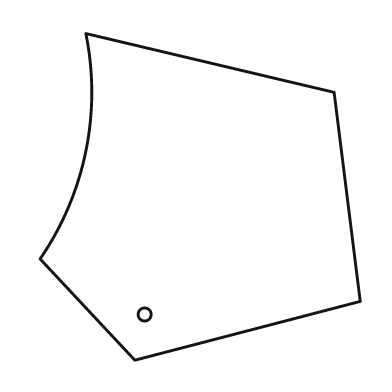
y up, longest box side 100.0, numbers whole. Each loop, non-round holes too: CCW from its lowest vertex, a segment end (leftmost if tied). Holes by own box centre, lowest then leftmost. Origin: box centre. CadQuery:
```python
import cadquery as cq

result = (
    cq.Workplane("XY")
    .moveTo(-20.0, -50.0)
    .lineTo(49.0, -32.0)
    .lineTo(41.0, 32.0)
    .lineTo(-35.0, 50.0)
    .threePointArc((-35.0, 14.0), (-49.0, -19.0))
    .close()
    .moveTo(-17.0, -36.0)
    .circle(2.0)
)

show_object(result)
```